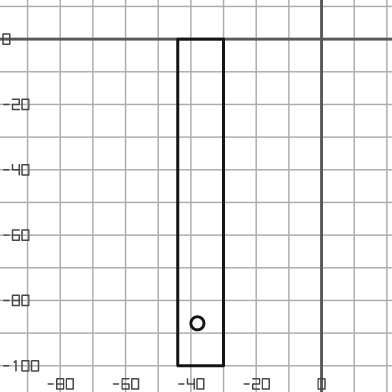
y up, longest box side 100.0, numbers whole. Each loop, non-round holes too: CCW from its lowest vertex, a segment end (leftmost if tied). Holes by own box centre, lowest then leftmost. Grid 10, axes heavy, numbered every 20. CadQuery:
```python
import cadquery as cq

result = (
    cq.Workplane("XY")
    .moveTo(-44.0, -100.0)
    .lineTo(-30.0, -100.0)
    .lineTo(-30.0, 0.0)
    .lineTo(-44.0, 0.0)
    .close()
    .moveTo(-38.0, -87.0)
    .circle(2.0)
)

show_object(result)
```